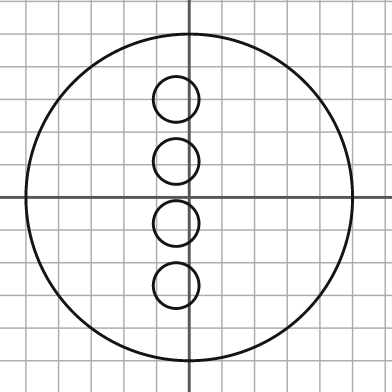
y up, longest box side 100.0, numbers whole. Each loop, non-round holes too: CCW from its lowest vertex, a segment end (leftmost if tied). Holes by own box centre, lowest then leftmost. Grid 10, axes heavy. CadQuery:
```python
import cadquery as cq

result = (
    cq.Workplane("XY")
    .moveTo(0.0, 0.0)
    .circle(50.0)
    .moveTo(-4.0, -27.0)
    .circle(7.0)
    .moveTo(-4.0, -8.0)
    .circle(7.0)
    .moveTo(-4.0, 11.0)
    .circle(7.0)
    .moveTo(-4.0, 30.0)
    .circle(7.0)
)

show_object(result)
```